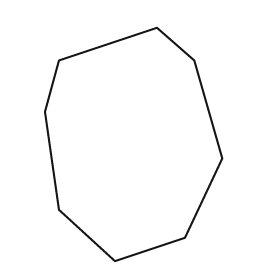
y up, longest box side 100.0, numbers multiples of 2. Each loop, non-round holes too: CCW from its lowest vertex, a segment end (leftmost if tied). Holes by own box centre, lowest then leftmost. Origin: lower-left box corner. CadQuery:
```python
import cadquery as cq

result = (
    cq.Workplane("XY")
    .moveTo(30.0, 0.0)
    .lineTo(60.0, 10.0)
    .lineTo(76.0, 44.0)
    .lineTo(64.0, 86.0)
    .lineTo(48.0, 100.0)
    .lineTo(6.0, 86.0)
    .lineTo(0.0, 64.0)
    .lineTo(6.0, 22.0)
    .close()
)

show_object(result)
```